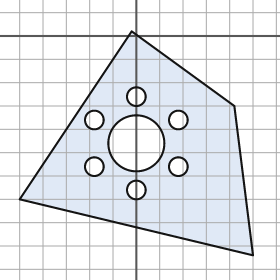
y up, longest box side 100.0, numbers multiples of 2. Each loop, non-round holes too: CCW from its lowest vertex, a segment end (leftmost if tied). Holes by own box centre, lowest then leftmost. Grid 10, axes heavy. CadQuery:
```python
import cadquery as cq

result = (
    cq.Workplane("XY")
    .moveTo(50.0, -94.0)
    .lineTo(42.0, -30.0)
    .lineTo(-2.0, 2.0)
    .lineTo(-50.0, -70.0)
    .close()
    .moveTo(0.0, -66.0)
    .circle(4.0)
    .moveTo(-18.0, -56.0)
    .circle(4.0)
    .moveTo(18.0, -56.0)
    .circle(4.0)
    .moveTo(0.0, -46.0)
    .circle(12.0)
    .moveTo(-18.0, -36.0)
    .circle(4.0)
    .moveTo(18.0, -36.0)
    .circle(4.0)
    .moveTo(0.0, -26.0)
    .circle(4.0)
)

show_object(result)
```